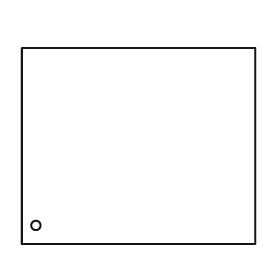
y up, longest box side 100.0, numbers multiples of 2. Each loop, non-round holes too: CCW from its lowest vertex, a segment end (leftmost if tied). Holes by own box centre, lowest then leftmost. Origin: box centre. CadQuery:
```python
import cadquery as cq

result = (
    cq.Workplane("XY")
    .moveTo(-50.0, -42.0)
    .lineTo(50.0, -42.0)
    .lineTo(50.0, 42.0)
    .lineTo(-50.0, 42.0)
    .close()
    .moveTo(-44.0, -34.0)
    .circle(2.0)
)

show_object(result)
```